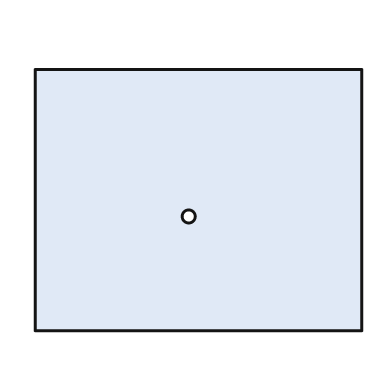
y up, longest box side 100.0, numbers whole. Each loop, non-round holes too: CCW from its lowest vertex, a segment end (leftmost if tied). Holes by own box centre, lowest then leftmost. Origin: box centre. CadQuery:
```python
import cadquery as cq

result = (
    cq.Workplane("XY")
    .moveTo(-50.0, -40.0)
    .lineTo(50.0, -40.0)
    .lineTo(50.0, 40.0)
    .lineTo(-50.0, 40.0)
    .close()
    .moveTo(-3.0, -5.0)
    .circle(2.0)
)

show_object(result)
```